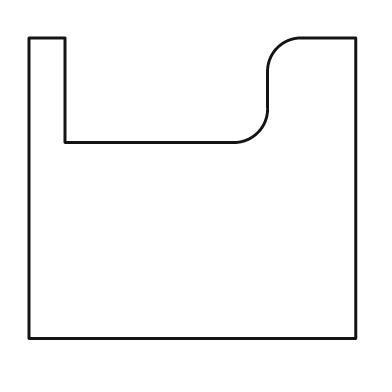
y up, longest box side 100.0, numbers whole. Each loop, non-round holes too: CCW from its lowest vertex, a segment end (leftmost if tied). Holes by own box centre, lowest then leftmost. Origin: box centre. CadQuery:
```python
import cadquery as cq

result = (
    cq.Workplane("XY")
    .moveTo(-50.0, -46.0)
    .lineTo(50.0, -46.0)
    .lineTo(50.0, 46.0)
    .lineTo(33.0, 46.0)
    .threePointArc((26.0, 43.0), (23.0, 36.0))
    .lineTo(23.0, 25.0)
    .threePointArc((20.0, 17.0), (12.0, 14.0))
    .lineTo(-39.0, 14.0)
    .lineTo(-39.0, 46.0)
    .lineTo(-50.0, 46.0)
    .close()
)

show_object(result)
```